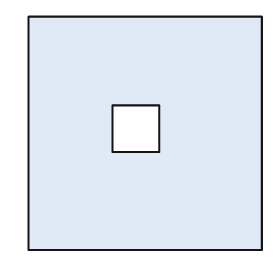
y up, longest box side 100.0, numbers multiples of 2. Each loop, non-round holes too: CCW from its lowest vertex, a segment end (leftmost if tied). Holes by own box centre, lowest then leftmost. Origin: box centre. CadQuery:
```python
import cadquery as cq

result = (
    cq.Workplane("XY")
    .moveTo(-50.0, -50.0)
    .lineTo(50.0, -50.0)
    .lineTo(50.0, 50.0)
    .lineTo(-50.0, 50.0)
    .close()
    .moveTo(-14.0, -8.0)
    .lineTo(6.0, -8.0)
    .lineTo(6.0, 12.0)
    .lineTo(-14.0, 12.0)
    .close()
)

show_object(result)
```